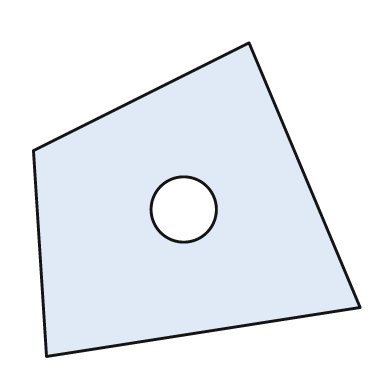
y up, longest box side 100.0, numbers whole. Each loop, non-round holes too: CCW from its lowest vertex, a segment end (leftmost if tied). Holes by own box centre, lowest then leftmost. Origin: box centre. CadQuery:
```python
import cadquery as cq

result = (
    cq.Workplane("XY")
    .moveTo(-46.0, -48.0)
    .lineTo(50.0, -33.0)
    .lineTo(16.0, 48.0)
    .lineTo(-50.0, 15.0)
    .close()
    .moveTo(-4.0, -3.0)
    .circle(10.0)
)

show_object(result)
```